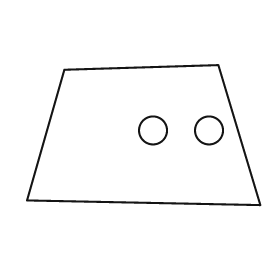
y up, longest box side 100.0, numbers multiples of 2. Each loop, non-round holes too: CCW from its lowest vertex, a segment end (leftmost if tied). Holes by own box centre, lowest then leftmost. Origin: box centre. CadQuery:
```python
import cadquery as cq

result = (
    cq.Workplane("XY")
    .moveTo(50.0, -30.0)
    .lineTo(32.0, 30.0)
    .lineTo(-34.0, 28.0)
    .lineTo(-50.0, -28.0)
    .close()
    .moveTo(4.0, 2.0)
    .circle(6.0)
    .moveTo(28.0, 2.0)
    .circle(6.0)
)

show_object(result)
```